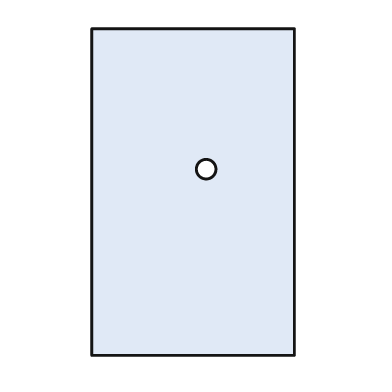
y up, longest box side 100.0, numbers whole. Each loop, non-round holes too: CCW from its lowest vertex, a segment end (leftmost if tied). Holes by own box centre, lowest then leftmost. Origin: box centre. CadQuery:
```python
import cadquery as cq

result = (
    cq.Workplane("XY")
    .moveTo(-31.0, -50.0)
    .lineTo(31.0, -50.0)
    .lineTo(31.0, 50.0)
    .lineTo(-31.0, 50.0)
    .close()
    .moveTo(4.0, 7.0)
    .circle(3.0)
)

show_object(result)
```